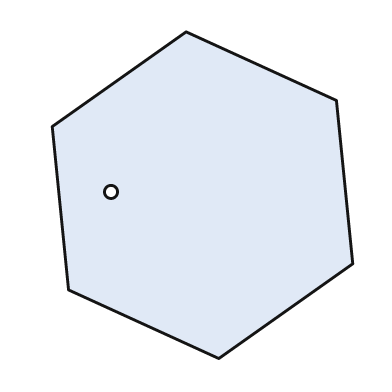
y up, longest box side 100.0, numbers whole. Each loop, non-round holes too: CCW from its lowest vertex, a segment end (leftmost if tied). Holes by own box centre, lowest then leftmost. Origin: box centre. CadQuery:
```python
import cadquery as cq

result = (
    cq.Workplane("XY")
    .moveTo(5.0, -50.0)
    .lineTo(46.0, -21.0)
    .lineTo(41.0, 29.0)
    .lineTo(-5.0, 50.0)
    .lineTo(-46.0, 21.0)
    .lineTo(-41.0, -29.0)
    .close()
    .moveTo(-28.0, 1.0)
    .circle(2.0)
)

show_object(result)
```